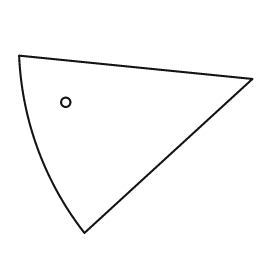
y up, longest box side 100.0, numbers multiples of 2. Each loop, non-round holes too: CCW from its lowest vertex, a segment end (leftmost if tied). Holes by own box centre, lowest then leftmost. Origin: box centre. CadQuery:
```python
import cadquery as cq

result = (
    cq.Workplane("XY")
    .moveTo(-22.0, -38.0)
    .lineTo(50.0, 28.0)
    .lineTo(-50.0, 38.0)
    .threePointArc((-42.0, -2.0), (-22.0, -38.0))
    .close()
    .moveTo(-30.0, 18.0)
    .circle(2.0)
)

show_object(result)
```